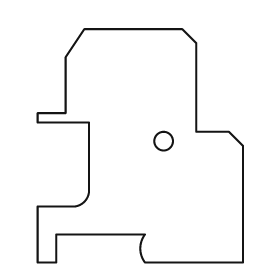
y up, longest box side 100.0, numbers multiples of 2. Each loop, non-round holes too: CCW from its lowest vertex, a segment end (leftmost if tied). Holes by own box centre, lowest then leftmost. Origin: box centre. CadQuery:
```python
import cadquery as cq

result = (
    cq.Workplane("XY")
    .moveTo(-44.0, -50.0)
    .lineTo(-36.0, -50.0)
    .lineTo(-36.0, -38.0)
    .lineTo(2.0, -38.0)
    .threePointArc((0.0, -44.0), (2.0, -50.0))
    .lineTo(44.0, -50.0)
    .lineTo(44.0, 0.0)
    .lineTo(38.0, 6.0)
    .lineTo(24.0, 6.0)
    .lineTo(24.0, 44.0)
    .lineTo(18.0, 50.0)
    .lineTo(-24.0, 50.0)
    .lineTo(-32.0, 38.0)
    .lineTo(-32.0, 14.0)
    .lineTo(-44.0, 14.0)
    .lineTo(-44.0, 10.0)
    .lineTo(-22.0, 10.0)
    .lineTo(-22.0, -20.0)
    .threePointArc((-24.0, -24.0), (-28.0, -26.0))
    .lineTo(-44.0, -26.0)
    .close()
    .moveTo(10.0, 2.0)
    .circle(4.0)
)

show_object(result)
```